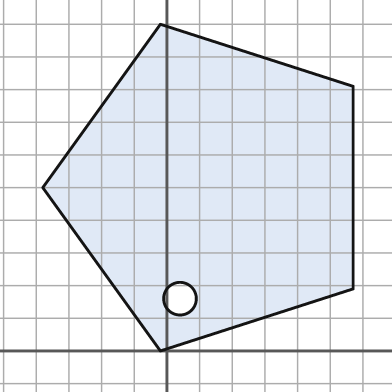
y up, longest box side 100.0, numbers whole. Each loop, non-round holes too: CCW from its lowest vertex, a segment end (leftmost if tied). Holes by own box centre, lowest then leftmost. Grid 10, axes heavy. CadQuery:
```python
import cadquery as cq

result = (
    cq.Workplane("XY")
    .moveTo(-2.0, 0.0)
    .lineTo(57.0, 19.0)
    .lineTo(57.0, 81.0)
    .lineTo(-2.0, 100.0)
    .lineTo(-38.0, 50.0)
    .close()
    .moveTo(4.0, 16.0)
    .circle(5.0)
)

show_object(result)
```